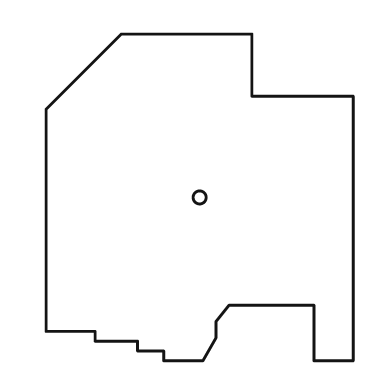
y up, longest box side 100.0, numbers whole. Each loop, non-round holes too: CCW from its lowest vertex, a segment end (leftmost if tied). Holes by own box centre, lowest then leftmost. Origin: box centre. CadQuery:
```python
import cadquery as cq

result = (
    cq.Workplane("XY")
    .moveTo(-11.0, -50.0)
    .lineTo(1.0, -50.0)
    .lineTo(5.0, -43.0)
    .lineTo(5.0, -38.0)
    .lineTo(9.0, -33.0)
    .lineTo(35.0, -33.0)
    .lineTo(35.0, -50.0)
    .lineTo(47.0, -50.0)
    .lineTo(47.0, 31.0)
    .lineTo(16.0, 31.0)
    .lineTo(16.0, 50.0)
    .lineTo(-24.0, 50.0)
    .lineTo(-47.0, 27.0)
    .lineTo(-47.0, -41.0)
    .lineTo(-32.0, -41.0)
    .lineTo(-32.0, -44.0)
    .lineTo(-19.0, -44.0)
    .lineTo(-19.0, -47.0)
    .lineTo(-11.0, -47.0)
    .close()
    .moveTo(0.0, 0.0)
    .circle(2.0)
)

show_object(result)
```